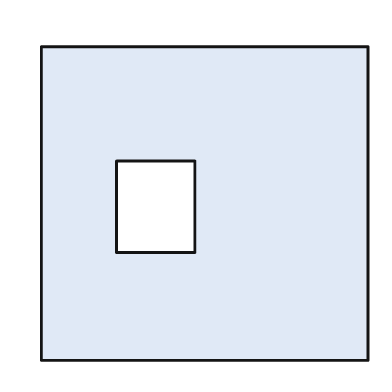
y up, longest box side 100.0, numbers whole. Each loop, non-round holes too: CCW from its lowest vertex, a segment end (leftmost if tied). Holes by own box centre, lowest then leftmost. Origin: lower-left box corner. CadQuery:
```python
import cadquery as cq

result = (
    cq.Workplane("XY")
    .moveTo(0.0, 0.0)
    .lineTo(100.0, 0.0)
    .lineTo(100.0, 96.0)
    .lineTo(0.0, 96.0)
    .close()
    .moveTo(23.0, 33.0)
    .lineTo(47.0, 33.0)
    .lineTo(47.0, 61.0)
    .lineTo(23.0, 61.0)
    .close()
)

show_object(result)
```